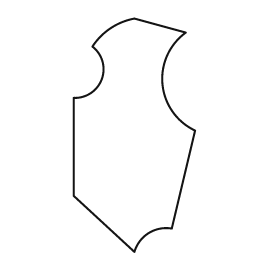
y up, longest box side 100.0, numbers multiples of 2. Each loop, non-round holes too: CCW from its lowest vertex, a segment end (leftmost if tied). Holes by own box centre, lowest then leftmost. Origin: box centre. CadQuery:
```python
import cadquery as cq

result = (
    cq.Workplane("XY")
    .moveTo(0.0, -50.0)
    .threePointArc((6.0, -42.0), (16.0, -40.0))
    .lineTo(26.0, 2.0)
    .threePointArc((12.0, 22.0), (22.0, 44.0))
    .lineTo(0.0, 50.0)
    .threePointArc((-10.0, 46.0), (-18.0, 38.0))
    .threePointArc((-14.0, 24.0), (-26.0, 16.0))
    .lineTo(-26.0, -26.0)
    .close()
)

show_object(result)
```